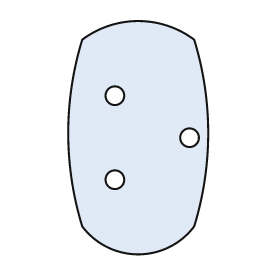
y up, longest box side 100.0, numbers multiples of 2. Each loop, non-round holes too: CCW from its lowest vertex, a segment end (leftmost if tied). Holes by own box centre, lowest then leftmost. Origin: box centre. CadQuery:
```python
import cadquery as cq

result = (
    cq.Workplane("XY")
    .moveTo(-24.0, -38.0)
    .threePointArc((0.0, -50.0), (24.0, -38.0))
    .threePointArc((30.0, 2.0), (24.0, 42.0))
    .threePointArc((0.0, 50.0), (-24.0, 42.0))
    .threePointArc((-30.0, 2.0), (-24.0, -38.0))
    .close()
    .moveTo(-10.0, -18.0)
    .circle(4.0)
    .moveTo(22.0, 0.0)
    .circle(4.0)
    .moveTo(-10.0, 18.0)
    .circle(4.0)
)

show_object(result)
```